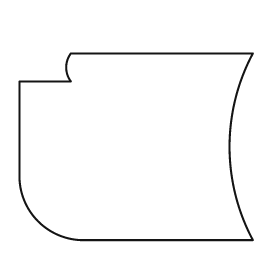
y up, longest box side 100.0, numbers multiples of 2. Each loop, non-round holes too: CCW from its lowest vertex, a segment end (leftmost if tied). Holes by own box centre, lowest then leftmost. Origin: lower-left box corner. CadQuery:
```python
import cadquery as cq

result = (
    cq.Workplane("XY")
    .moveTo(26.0, 0.0)
    .lineTo(100.0, 0.0)
    .threePointArc((90.0, 40.0), (100.0, 80.0))
    .lineTo(22.0, 80.0)
    .threePointArc((20.0, 74.0), (22.0, 68.0))
    .lineTo(0.0, 68.0)
    .lineTo(0.0, 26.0)
    .threePointArc((8.0, 8.0), (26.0, 0.0))
    .close()
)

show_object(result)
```